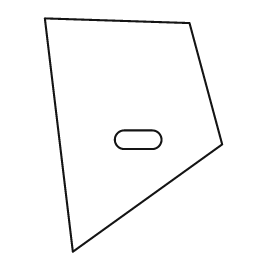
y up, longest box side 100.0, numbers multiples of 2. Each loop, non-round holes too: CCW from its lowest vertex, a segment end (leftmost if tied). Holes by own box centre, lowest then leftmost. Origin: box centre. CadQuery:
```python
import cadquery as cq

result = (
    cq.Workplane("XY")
    .moveTo(-26.0, -50.0)
    .lineTo(38.0, -4.0)
    .lineTo(24.0, 48.0)
    .lineTo(-38.0, 50.0)
    .close()
    .moveTo(-4.0, -6.0)
    .lineTo(8.0, -6.0)
    .threePointArc((12.0, -2.0), (8.0, 2.0))
    .lineTo(-4.0, 2.0)
    .threePointArc((-8.0, -2.0), (-4.0, -6.0))
    .close()
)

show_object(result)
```